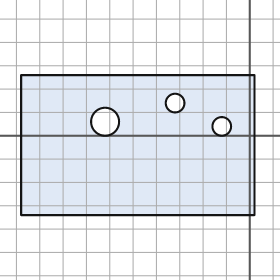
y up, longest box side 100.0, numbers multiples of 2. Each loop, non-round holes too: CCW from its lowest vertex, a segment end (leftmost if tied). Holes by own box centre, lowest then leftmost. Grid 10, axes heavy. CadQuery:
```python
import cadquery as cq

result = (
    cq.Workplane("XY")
    .moveTo(-98.0, -34.0)
    .lineTo(2.0, -34.0)
    .lineTo(2.0, 26.0)
    .lineTo(-98.0, 26.0)
    .close()
    .moveTo(-12.0, 4.0)
    .circle(4.0)
    .moveTo(-62.0, 6.0)
    .circle(6.0)
    .moveTo(-32.0, 14.0)
    .circle(4.0)
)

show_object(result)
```